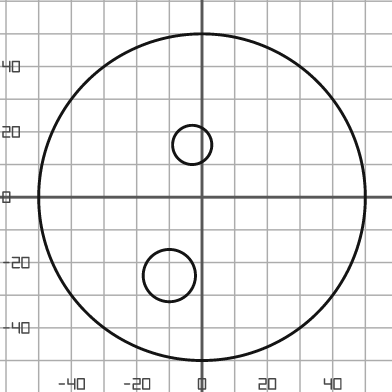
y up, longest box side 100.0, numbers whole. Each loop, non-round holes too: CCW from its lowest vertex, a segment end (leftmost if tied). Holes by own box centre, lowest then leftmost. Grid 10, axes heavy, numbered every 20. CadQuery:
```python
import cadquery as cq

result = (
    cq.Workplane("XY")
    .moveTo(0.0, 0.0)
    .circle(50.0)
    .moveTo(-10.0, -24.0)
    .circle(8.0)
    .moveTo(-3.0, 16.0)
    .circle(6.0)
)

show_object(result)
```